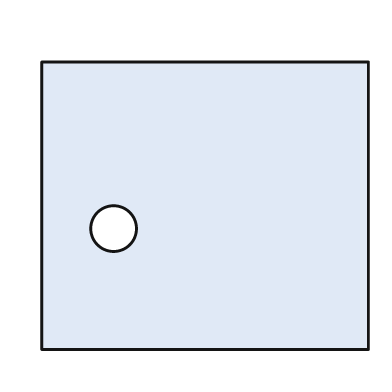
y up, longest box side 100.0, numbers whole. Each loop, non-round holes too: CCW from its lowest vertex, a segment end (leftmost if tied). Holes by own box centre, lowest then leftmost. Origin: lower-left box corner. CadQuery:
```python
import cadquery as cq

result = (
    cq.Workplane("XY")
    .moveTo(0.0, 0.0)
    .lineTo(100.0, 0.0)
    .lineTo(100.0, 88.0)
    .lineTo(0.0, 88.0)
    .close()
    .moveTo(22.0, 37.0)
    .circle(7.0)
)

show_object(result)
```